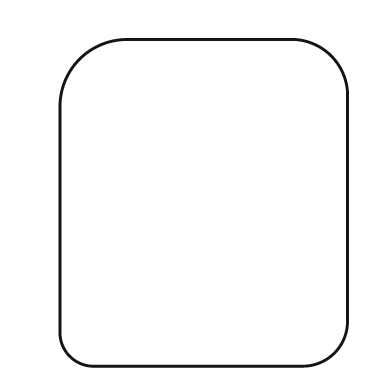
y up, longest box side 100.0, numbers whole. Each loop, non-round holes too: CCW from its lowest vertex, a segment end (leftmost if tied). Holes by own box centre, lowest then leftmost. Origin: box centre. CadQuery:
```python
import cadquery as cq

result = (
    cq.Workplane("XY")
    .moveTo(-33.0, -50.0)
    .lineTo(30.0, -50.0)
    .threePointArc((40.0, -46.0), (44.0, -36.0))
    .lineTo(44.0, 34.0)
    .threePointArc((39.0, 45.0), (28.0, 50.0))
    .lineTo(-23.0, 50.0)
    .threePointArc((-38.0, 44.0), (-44.0, 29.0))
    .lineTo(-44.0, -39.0)
    .threePointArc((-41.0, -47.0), (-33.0, -50.0))
    .close()
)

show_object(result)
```